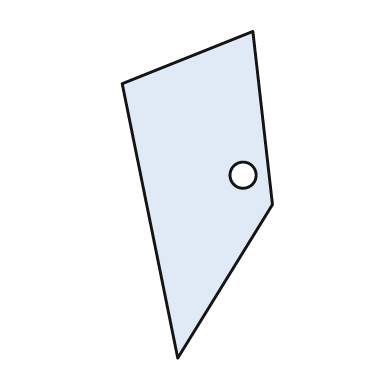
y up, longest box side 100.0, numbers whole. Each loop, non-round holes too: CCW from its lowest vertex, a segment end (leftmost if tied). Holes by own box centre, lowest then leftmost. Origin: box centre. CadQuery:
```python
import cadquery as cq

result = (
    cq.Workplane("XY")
    .moveTo(-6.0, -50.0)
    .lineTo(23.0, -3.0)
    .lineTo(17.0, 50.0)
    .lineTo(-23.0, 34.0)
    .close()
    .moveTo(14.0, 6.0)
    .circle(4.0)
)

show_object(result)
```